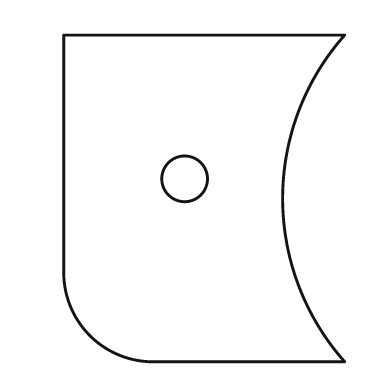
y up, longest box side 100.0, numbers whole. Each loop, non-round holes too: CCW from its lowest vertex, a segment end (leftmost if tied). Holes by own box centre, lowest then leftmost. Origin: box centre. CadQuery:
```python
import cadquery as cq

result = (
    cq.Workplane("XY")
    .moveTo(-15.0, -50.0)
    .lineTo(43.0, -50.0)
    .threePointArc((24.0, 0.0), (43.0, 50.0))
    .lineTo(-43.0, 50.0)
    .lineTo(-43.0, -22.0)
    .threePointArc((-35.0, -42.0), (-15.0, -50.0))
    .close()
    .moveTo(-6.0, 6.0)
    .circle(7.0)
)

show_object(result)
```